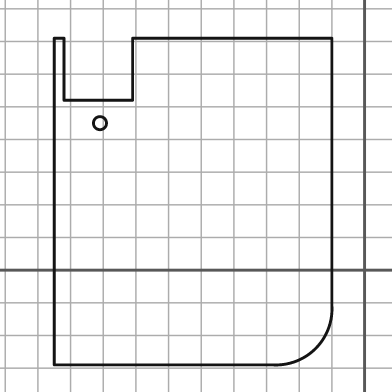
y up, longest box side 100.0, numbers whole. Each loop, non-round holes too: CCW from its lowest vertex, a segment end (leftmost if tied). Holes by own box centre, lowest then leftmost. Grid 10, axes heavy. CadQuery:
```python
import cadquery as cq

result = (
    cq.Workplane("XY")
    .moveTo(-95.0, -29.0)
    .lineTo(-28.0, -29.0)
    .threePointArc((-15.0, -24.0), (-10.0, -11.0))
    .lineTo(-10.0, 71.0)
    .lineTo(-71.0, 71.0)
    .lineTo(-71.0, 52.0)
    .lineTo(-92.0, 52.0)
    .lineTo(-92.0, 71.0)
    .lineTo(-95.0, 71.0)
    .close()
    .moveTo(-81.0, 45.0)
    .circle(2.0)
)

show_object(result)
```